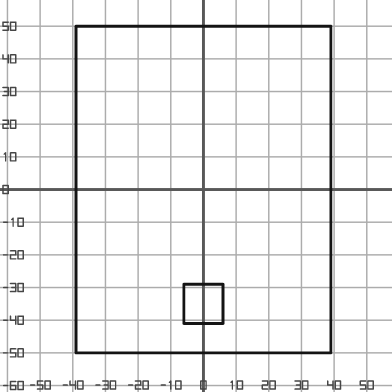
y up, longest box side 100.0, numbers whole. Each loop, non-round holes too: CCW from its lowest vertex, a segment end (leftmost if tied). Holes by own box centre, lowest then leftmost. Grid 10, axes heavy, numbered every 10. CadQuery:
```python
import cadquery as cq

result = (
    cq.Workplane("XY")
    .moveTo(-39.0, -50.0)
    .lineTo(39.0, -50.0)
    .lineTo(39.0, 50.0)
    .lineTo(-39.0, 50.0)
    .close()
    .moveTo(-6.0, -41.0)
    .lineTo(6.0, -41.0)
    .lineTo(6.0, -29.0)
    .lineTo(-6.0, -29.0)
    .close()
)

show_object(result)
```